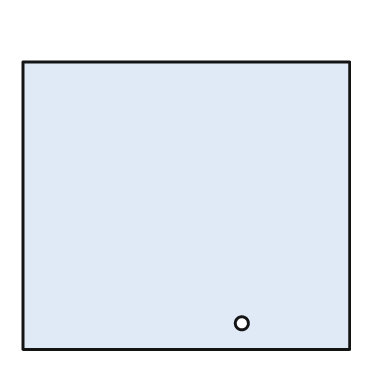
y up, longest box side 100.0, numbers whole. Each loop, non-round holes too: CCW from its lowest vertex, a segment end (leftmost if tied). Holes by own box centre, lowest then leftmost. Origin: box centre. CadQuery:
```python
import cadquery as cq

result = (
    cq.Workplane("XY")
    .moveTo(-50.0, -44.0)
    .lineTo(50.0, -44.0)
    .lineTo(50.0, 44.0)
    .lineTo(-50.0, 44.0)
    .close()
    .moveTo(17.0, -36.0)
    .circle(2.0)
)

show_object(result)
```